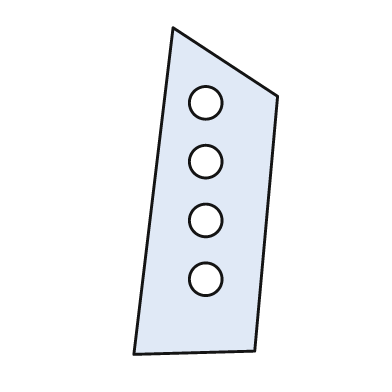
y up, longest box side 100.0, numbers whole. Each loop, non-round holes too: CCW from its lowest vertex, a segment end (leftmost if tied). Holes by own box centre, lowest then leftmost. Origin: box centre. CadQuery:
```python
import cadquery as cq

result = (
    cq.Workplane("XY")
    .moveTo(-22.0, -50.0)
    .lineTo(15.0, -49.0)
    .lineTo(22.0, 29.0)
    .lineTo(-10.0, 50.0)
    .close()
    .moveTo(0.0, -27.0)
    .circle(5.0)
    .moveTo(0.0, -9.0)
    .circle(5.0)
    .moveTo(0.0, 9.0)
    .circle(5.0)
    .moveTo(0.0, 27.0)
    .circle(5.0)
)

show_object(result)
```